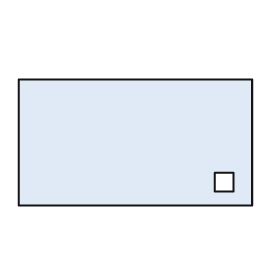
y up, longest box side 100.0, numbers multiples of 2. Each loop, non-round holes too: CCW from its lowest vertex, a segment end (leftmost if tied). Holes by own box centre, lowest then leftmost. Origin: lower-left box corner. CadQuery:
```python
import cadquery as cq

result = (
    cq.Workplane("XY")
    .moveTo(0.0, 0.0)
    .lineTo(100.0, 0.0)
    .lineTo(100.0, 54.0)
    .lineTo(0.0, 54.0)
    .close()
    .moveTo(84.0, 6.0)
    .lineTo(92.0, 6.0)
    .lineTo(92.0, 14.0)
    .lineTo(84.0, 14.0)
    .close()
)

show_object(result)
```